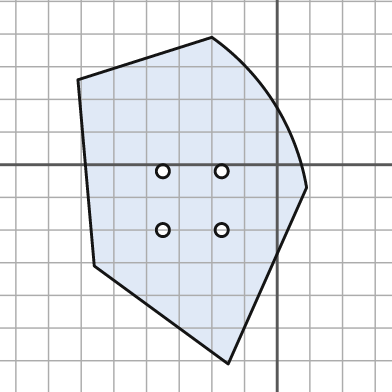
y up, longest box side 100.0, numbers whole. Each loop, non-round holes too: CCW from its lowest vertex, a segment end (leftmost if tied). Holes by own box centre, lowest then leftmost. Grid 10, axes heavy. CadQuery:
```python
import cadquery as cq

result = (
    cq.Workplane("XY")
    .moveTo(-15.0, -61.0)
    .lineTo(9.0, -7.0)
    .threePointArc((-1.0, 19.0), (-20.0, 39.0))
    .lineTo(-61.0, 26.0)
    .lineTo(-56.0, -31.0)
    .close()
    .moveTo(-35.0, -20.0)
    .circle(2.0)
    .moveTo(-17.0, -20.0)
    .circle(2.0)
    .moveTo(-35.0, -2.0)
    .circle(2.0)
    .moveTo(-17.0, -2.0)
    .circle(2.0)
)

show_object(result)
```